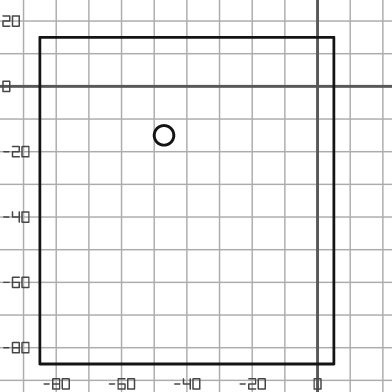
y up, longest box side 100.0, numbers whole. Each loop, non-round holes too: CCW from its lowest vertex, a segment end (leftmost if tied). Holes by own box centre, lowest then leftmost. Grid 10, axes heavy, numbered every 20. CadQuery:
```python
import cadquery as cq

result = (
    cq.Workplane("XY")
    .moveTo(-85.0, -85.0)
    .lineTo(5.0, -85.0)
    .lineTo(5.0, 15.0)
    .lineTo(-85.0, 15.0)
    .close()
    .moveTo(-47.0, -15.0)
    .circle(3.0)
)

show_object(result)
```